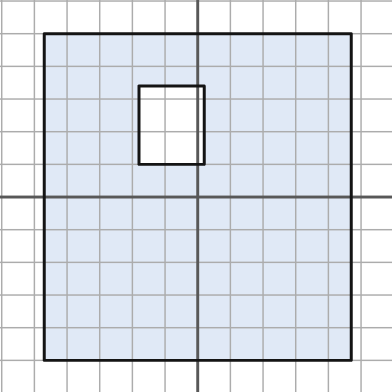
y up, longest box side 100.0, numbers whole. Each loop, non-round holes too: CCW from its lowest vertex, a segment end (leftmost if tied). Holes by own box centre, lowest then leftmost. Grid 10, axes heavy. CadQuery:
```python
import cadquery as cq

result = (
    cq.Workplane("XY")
    .moveTo(-47.0, -50.0)
    .lineTo(47.0, -50.0)
    .lineTo(47.0, 50.0)
    .lineTo(-47.0, 50.0)
    .close()
    .moveTo(-18.0, 10.0)
    .lineTo(2.0, 10.0)
    .lineTo(2.0, 34.0)
    .lineTo(-18.0, 34.0)
    .close()
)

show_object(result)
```